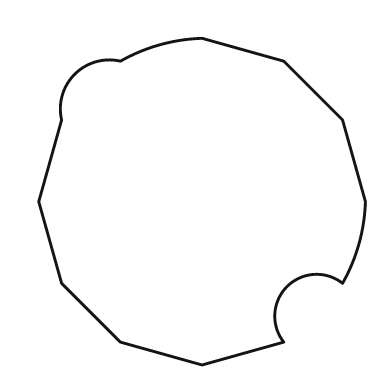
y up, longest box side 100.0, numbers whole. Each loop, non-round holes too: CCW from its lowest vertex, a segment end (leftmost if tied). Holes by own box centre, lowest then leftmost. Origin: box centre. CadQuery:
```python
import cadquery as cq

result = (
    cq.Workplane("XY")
    .moveTo(0.0, -50.0)
    .lineTo(25.0, -43.0)
    .threePointArc((26.0, -26.0), (43.0, -25.0))
    .threePointArc((48.0, -13.0), (50.0, 0.0))
    .lineTo(43.0, 25.0)
    .lineTo(25.0, 43.0)
    .lineTo(0.0, 50.0)
    .threePointArc((-13.0, 48.0), (-25.0, 43.0))
    .threePointArc((-39.0, 39.0), (-43.0, 25.0))
    .lineTo(-50.0, 0.0)
    .lineTo(-43.0, -25.0)
    .lineTo(-25.0, -43.0)
    .close()
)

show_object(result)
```